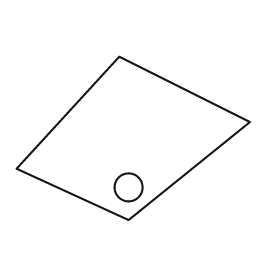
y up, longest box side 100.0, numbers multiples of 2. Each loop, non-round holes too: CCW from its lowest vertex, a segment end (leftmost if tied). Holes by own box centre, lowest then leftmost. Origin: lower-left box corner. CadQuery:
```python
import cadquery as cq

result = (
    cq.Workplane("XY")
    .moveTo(48.0, 0.0)
    .lineTo(100.0, 42.0)
    .lineTo(44.0, 70.0)
    .lineTo(0.0, 22.0)
    .close()
    .moveTo(48.0, 14.0)
    .circle(6.0)
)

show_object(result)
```